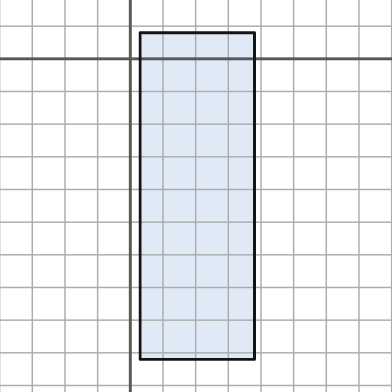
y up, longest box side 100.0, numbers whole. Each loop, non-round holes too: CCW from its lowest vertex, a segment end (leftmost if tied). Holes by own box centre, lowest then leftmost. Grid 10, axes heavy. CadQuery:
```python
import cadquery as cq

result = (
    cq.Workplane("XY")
    .moveTo(3.0, -92.0)
    .lineTo(38.0, -92.0)
    .lineTo(38.0, 8.0)
    .lineTo(3.0, 8.0)
    .close()
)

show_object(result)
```